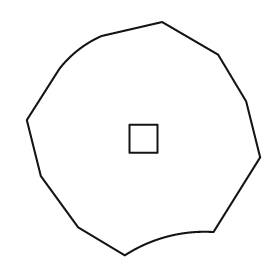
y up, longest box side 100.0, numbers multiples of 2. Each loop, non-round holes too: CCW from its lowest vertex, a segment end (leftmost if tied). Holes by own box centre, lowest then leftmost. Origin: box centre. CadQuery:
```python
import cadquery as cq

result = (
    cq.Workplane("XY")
    .moveTo(-8.0, -50.0)
    .threePointArc((10.0, -42.0), (30.0, -40.0))
    .lineTo(50.0, -8.0)
    .lineTo(44.0, 16.0)
    .lineTo(32.0, 36.0)
    .lineTo(8.0, 50.0)
    .lineTo(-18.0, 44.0)
    .threePointArc((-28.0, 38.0), (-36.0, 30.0))
    .lineTo(-50.0, 8.0)
    .lineTo(-44.0, -16.0)
    .lineTo(-28.0, -38.0)
    .close()
    .moveTo(-6.0, -6.0)
    .lineTo(6.0, -6.0)
    .lineTo(6.0, 6.0)
    .lineTo(-6.0, 6.0)
    .close()
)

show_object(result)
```